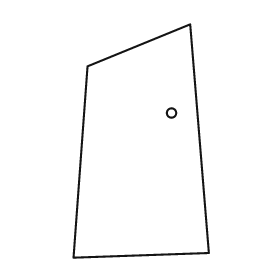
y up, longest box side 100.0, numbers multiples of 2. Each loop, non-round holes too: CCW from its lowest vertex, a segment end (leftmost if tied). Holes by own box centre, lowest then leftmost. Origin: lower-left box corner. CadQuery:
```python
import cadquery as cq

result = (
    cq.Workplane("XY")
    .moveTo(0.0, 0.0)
    .lineTo(58.0, 2.0)
    .lineTo(50.0, 100.0)
    .lineTo(6.0, 82.0)
    .close()
    .moveTo(42.0, 62.0)
    .circle(2.0)
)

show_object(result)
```